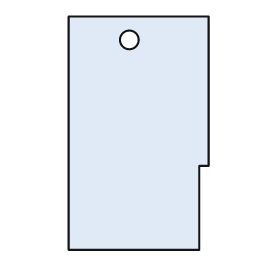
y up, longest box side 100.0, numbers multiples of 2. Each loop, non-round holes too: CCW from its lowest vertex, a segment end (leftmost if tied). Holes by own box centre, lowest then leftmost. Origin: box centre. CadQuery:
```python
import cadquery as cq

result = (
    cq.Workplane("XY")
    .moveTo(-30.0, -50.0)
    .lineTo(26.0, -50.0)
    .lineTo(26.0, -14.0)
    .lineTo(30.0, -14.0)
    .lineTo(30.0, 50.0)
    .lineTo(-30.0, 50.0)
    .close()
    .moveTo(-4.0, 40.0)
    .circle(4.0)
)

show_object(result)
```